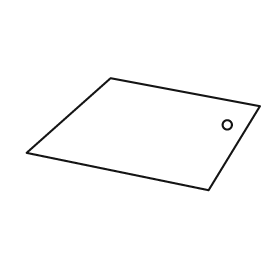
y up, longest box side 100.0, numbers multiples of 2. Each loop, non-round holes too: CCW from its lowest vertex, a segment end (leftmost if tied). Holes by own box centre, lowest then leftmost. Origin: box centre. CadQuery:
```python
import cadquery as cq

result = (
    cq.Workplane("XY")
    .moveTo(28.0, -24.0)
    .lineTo(50.0, 12.0)
    .lineTo(-14.0, 24.0)
    .lineTo(-50.0, -8.0)
    .close()
    .moveTo(36.0, 4.0)
    .circle(2.0)
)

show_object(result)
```